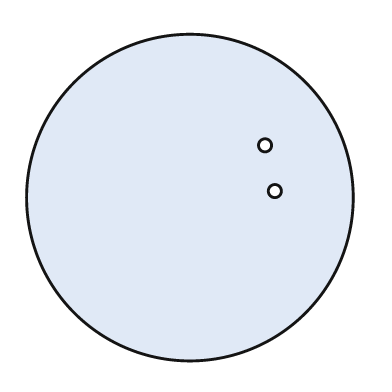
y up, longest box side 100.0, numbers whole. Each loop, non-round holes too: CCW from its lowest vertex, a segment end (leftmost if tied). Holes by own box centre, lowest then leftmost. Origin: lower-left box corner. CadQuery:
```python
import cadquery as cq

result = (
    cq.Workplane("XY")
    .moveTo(50.0, 50.0)
    .circle(50.0)
    .moveTo(76.0, 52.0)
    .circle(2.0)
    .moveTo(73.0, 66.0)
    .circle(2.0)
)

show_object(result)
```